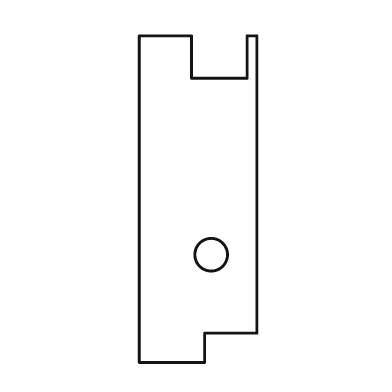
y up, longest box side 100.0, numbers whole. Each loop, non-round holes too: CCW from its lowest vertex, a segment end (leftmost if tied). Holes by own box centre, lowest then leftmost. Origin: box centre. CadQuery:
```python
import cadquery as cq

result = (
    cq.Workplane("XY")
    .moveTo(-18.0, -50.0)
    .lineTo(2.0, -50.0)
    .lineTo(2.0, -41.0)
    .lineTo(18.0, -41.0)
    .lineTo(18.0, 50.0)
    .lineTo(15.0, 50.0)
    .lineTo(15.0, 37.0)
    .lineTo(-2.0, 37.0)
    .lineTo(-2.0, 50.0)
    .lineTo(-18.0, 50.0)
    .close()
    .moveTo(4.0, -17.0)
    .circle(5.0)
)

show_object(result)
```